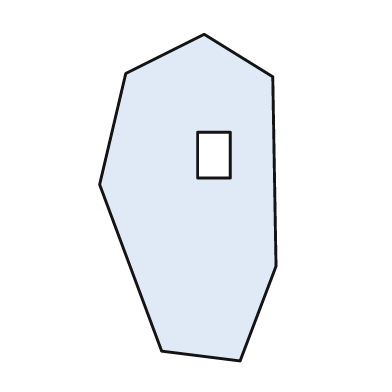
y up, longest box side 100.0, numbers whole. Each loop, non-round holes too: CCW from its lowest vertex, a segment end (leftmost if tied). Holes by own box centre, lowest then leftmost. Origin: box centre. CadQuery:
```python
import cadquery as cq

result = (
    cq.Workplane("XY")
    .moveTo(16.0, -50.0)
    .lineTo(27.0, -21.0)
    .lineTo(26.0, 37.0)
    .lineTo(5.0, 50.0)
    .lineTo(-19.0, 38.0)
    .lineTo(-27.0, 4.0)
    .lineTo(-8.0, -47.0)
    .close()
    .moveTo(3.0, 6.0)
    .lineTo(13.0, 6.0)
    .lineTo(13.0, 20.0)
    .lineTo(3.0, 20.0)
    .close()
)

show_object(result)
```